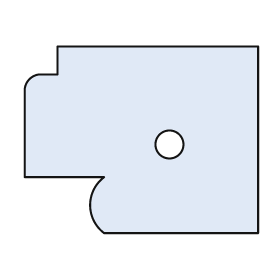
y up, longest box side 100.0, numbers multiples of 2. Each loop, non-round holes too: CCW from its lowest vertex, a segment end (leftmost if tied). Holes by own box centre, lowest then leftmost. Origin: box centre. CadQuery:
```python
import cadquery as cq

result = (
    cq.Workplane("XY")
    .moveTo(-16.0, -40.0)
    .lineTo(50.0, -40.0)
    .lineTo(50.0, 40.0)
    .lineTo(-36.0, 40.0)
    .lineTo(-36.0, 28.0)
    .lineTo(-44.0, 28.0)
    .threePointArc((-48.0, 26.0), (-50.0, 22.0))
    .lineTo(-50.0, -16.0)
    .lineTo(-16.0, -16.0)
    .threePointArc((-22.0, -28.0), (-16.0, -40.0))
    .close()
    .moveTo(12.0, -2.0)
    .circle(6.0)
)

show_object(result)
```